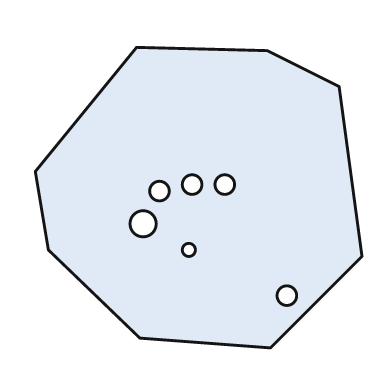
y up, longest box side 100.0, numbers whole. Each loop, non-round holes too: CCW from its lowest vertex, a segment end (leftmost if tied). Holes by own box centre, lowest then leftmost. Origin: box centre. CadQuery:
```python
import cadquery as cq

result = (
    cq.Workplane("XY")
    .moveTo(22.0, -46.0)
    .lineTo(50.0, -18.0)
    .lineTo(43.0, 34.0)
    .lineTo(21.0, 45.0)
    .lineTo(-19.0, 46.0)
    .lineTo(-50.0, 8.0)
    .lineTo(-46.0, -16.0)
    .lineTo(-18.0, -43.0)
    .close()
    .moveTo(27.0, -30.0)
    .circle(3.0)
    .moveTo(-3.0, -16.0)
    .circle(2.0)
    .moveTo(-17.0, -8.0)
    .circle(4.0)
    .moveTo(-12.0, 2.0)
    .circle(3.0)
    .moveTo(-2.0, 4.0)
    .circle(3.0)
    .moveTo(8.0, 4.0)
    .circle(3.0)
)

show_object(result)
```